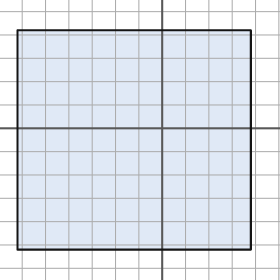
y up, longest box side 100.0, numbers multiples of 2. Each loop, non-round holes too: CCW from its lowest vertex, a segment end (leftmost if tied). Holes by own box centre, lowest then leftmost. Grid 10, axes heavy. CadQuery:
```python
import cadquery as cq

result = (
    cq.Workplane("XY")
    .moveTo(-62.0, -52.0)
    .lineTo(38.0, -52.0)
    .lineTo(38.0, 42.0)
    .lineTo(-62.0, 42.0)
    .close()
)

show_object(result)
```